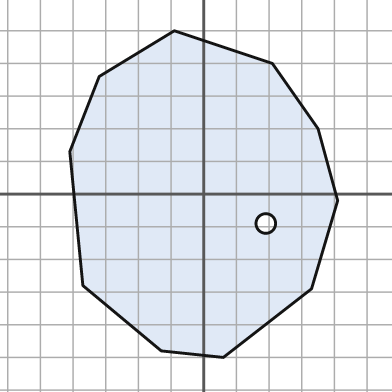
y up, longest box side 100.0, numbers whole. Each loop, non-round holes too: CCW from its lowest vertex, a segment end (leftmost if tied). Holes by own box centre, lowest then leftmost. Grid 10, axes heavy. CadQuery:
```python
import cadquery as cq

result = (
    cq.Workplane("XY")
    .moveTo(6.0, -50.0)
    .lineTo(33.0, -29.0)
    .lineTo(41.0, -2.0)
    .lineTo(35.0, 20.0)
    .lineTo(21.0, 40.0)
    .lineTo(-9.0, 50.0)
    .lineTo(-32.0, 36.0)
    .lineTo(-41.0, 13.0)
    .lineTo(-37.0, -28.0)
    .lineTo(-13.0, -48.0)
    .close()
    .moveTo(19.0, -9.0)
    .circle(3.0)
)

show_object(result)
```